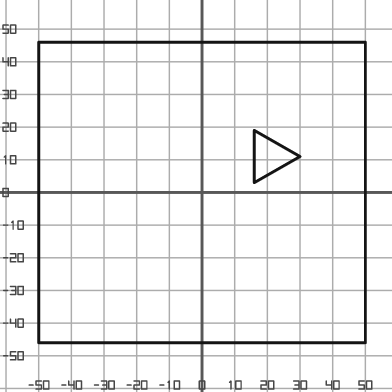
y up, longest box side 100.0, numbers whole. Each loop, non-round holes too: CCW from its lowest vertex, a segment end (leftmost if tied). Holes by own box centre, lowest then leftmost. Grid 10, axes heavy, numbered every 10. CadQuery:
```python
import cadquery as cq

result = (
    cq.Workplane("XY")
    .moveTo(-50.0, -46.0)
    .lineTo(50.0, -46.0)
    .lineTo(50.0, 46.0)
    .lineTo(-50.0, 46.0)
    .close()
    .moveTo(16.0, 3.0)
    .lineTo(30.0, 11.0)
    .lineTo(16.0, 19.0)
    .close()
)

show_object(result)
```